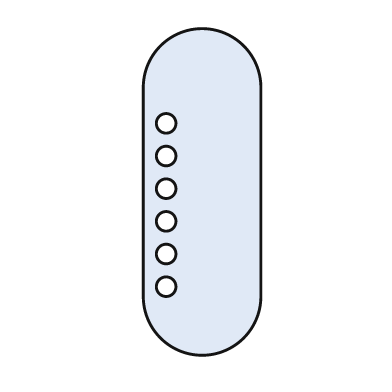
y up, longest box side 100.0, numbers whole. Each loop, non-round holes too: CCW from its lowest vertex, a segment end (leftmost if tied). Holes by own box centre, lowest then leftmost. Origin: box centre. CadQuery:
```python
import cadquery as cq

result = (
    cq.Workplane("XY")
    .moveTo(-18.0, -32.0)
    .threePointArc((0.0, -50.0), (18.0, -32.0))
    .lineTo(18.0, 32.0)
    .threePointArc((0.0, 50.0), (-18.0, 32.0))
    .close()
    .moveTo(-11.0, -29.0)
    .circle(3.0)
    .moveTo(-11.0, -19.0)
    .circle(3.0)
    .moveTo(-11.0, -9.0)
    .circle(3.0)
    .moveTo(-11.0, 1.0)
    .circle(3.0)
    .moveTo(-11.0, 11.0)
    .circle(3.0)
    .moveTo(-11.0, 21.0)
    .circle(3.0)
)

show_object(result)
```